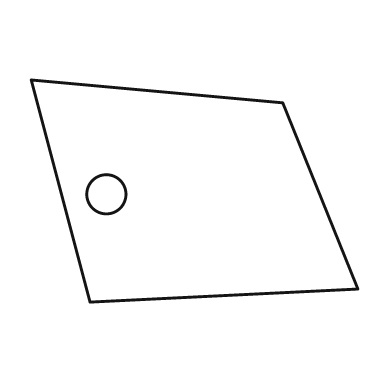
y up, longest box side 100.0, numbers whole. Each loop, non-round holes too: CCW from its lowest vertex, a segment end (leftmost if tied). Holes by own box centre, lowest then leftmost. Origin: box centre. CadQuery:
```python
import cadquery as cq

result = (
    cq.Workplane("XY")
    .moveTo(-32.0, -34.0)
    .lineTo(50.0, -30.0)
    .lineTo(27.0, 27.0)
    .lineTo(-50.0, 34.0)
    .close()
    .moveTo(-27.0, -1.0)
    .circle(6.0)
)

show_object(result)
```